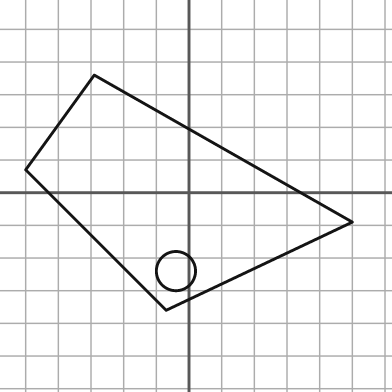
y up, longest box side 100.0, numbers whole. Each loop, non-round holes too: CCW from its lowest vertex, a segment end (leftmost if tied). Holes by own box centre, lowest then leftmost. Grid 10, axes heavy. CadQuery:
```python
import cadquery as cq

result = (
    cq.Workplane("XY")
    .moveTo(-7.0, -36.0)
    .lineTo(50.0, -9.0)
    .lineTo(-29.0, 36.0)
    .lineTo(-50.0, 7.0)
    .close()
    .moveTo(-4.0, -24.0)
    .circle(6.0)
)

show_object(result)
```